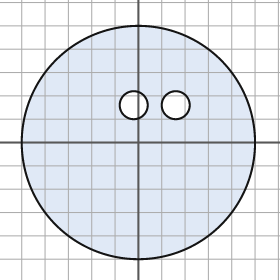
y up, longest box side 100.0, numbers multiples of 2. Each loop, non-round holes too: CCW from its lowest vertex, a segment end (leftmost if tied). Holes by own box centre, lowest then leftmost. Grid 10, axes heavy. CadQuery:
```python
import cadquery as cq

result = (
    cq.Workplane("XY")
    .moveTo(0.0, 0.0)
    .circle(50.0)
    .moveTo(-2.0, 16.0)
    .circle(6.0)
    .moveTo(16.0, 16.0)
    .circle(6.0)
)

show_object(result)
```